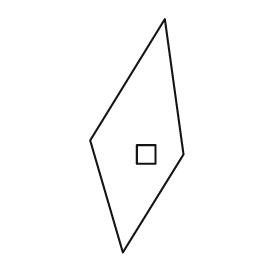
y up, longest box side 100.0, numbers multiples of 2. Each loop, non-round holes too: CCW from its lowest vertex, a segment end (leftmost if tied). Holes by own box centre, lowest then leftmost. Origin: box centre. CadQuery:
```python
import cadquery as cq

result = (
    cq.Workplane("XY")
    .moveTo(-6.0, -50.0)
    .lineTo(20.0, -8.0)
    .lineTo(12.0, 50.0)
    .lineTo(-20.0, -2.0)
    .close()
    .moveTo(0.0, -12.0)
    .lineTo(8.0, -12.0)
    .lineTo(8.0, -4.0)
    .lineTo(0.0, -4.0)
    .close()
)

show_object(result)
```